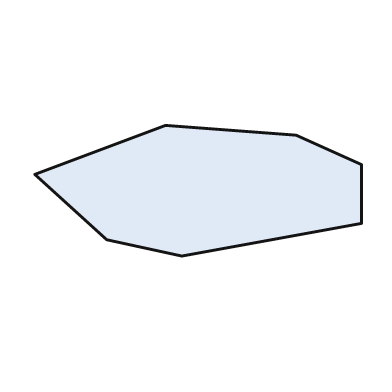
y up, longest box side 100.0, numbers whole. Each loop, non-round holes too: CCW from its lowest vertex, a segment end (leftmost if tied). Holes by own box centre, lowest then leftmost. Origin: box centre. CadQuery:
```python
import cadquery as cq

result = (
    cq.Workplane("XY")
    .moveTo(-5.0, -20.0)
    .lineTo(50.0, -10.0)
    .lineTo(50.0, 8.0)
    .lineTo(30.0, 17.0)
    .lineTo(-10.0, 20.0)
    .lineTo(-50.0, 5.0)
    .lineTo(-28.0, -15.0)
    .close()
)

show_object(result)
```